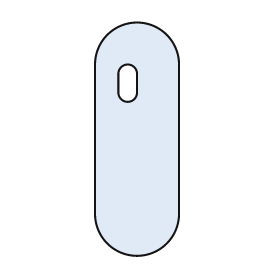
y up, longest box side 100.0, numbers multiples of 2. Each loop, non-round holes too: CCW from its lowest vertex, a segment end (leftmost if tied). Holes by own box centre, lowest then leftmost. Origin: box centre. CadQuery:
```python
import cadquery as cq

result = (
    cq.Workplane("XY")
    .moveTo(-18.0, -32.0)
    .threePointArc((0.0, -50.0), (18.0, -32.0))
    .lineTo(18.0, 32.0)
    .threePointArc((0.0, 50.0), (-18.0, 32.0))
    .close()
    .moveTo(-8.0, 20.0)
    .threePointArc((-4.0, 16.0), (0.0, 20.0))
    .lineTo(0.0, 28.0)
    .threePointArc((-4.0, 32.0), (-8.0, 28.0))
    .close()
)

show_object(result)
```